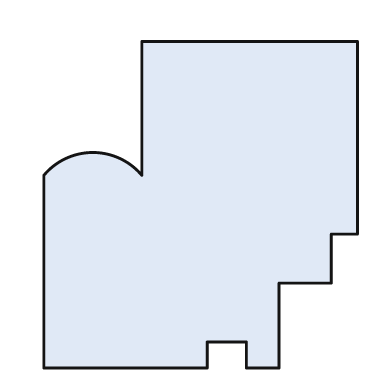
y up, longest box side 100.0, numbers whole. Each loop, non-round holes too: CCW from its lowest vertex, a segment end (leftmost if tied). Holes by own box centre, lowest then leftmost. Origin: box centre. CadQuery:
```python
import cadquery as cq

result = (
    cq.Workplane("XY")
    .moveTo(-48.0, -50.0)
    .lineTo(2.0, -50.0)
    .lineTo(2.0, -42.0)
    .lineTo(14.0, -42.0)
    .lineTo(14.0, -50.0)
    .lineTo(24.0, -50.0)
    .lineTo(24.0, -24.0)
    .lineTo(40.0, -24.0)
    .lineTo(40.0, -9.0)
    .lineTo(48.0, -9.0)
    .lineTo(48.0, 50.0)
    .lineTo(-18.0, 50.0)
    .lineTo(-18.0, 9.0)
    .threePointArc((-33.0, 16.0), (-48.0, 9.0))
    .close()
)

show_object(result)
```